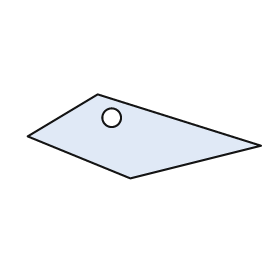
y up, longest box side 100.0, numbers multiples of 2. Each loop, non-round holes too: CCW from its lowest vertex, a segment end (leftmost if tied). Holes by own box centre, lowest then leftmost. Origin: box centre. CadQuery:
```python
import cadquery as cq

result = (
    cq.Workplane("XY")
    .moveTo(-6.0, -18.0)
    .lineTo(50.0, -4.0)
    .lineTo(-20.0, 18.0)
    .lineTo(-50.0, 0.0)
    .close()
    .moveTo(-14.0, 8.0)
    .circle(4.0)
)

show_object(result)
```